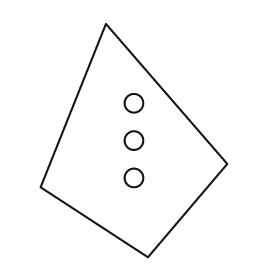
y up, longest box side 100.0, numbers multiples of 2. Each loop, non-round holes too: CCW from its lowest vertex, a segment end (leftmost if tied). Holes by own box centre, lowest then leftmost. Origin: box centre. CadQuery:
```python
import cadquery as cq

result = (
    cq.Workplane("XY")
    .moveTo(6.0, -50.0)
    .lineTo(40.0, -10.0)
    .lineTo(-12.0, 50.0)
    .lineTo(-40.0, -20.0)
    .close()
    .moveTo(0.0, -16.0)
    .circle(4.0)
    .moveTo(0.0, 0.0)
    .circle(4.0)
    .moveTo(0.0, 16.0)
    .circle(4.0)
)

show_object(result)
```